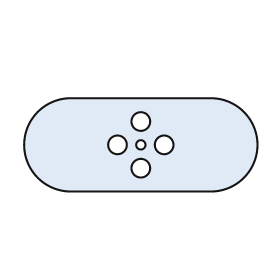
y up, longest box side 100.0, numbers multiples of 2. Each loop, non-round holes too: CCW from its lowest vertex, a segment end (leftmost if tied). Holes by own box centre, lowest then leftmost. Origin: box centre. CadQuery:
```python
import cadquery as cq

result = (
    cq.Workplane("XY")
    .moveTo(-30.0, -20.0)
    .lineTo(30.0, -20.0)
    .threePointArc((50.0, 0.0), (30.0, 20.0))
    .lineTo(-30.0, 20.0)
    .threePointArc((-50.0, 0.0), (-30.0, -20.0))
    .close()
    .moveTo(0.0, -10.0)
    .circle(4.0)
    .moveTo(-10.0, 0.0)
    .circle(4.0)
    .moveTo(0.0, 0.0)
    .circle(2.0)
    .moveTo(10.0, 0.0)
    .circle(4.0)
    .moveTo(0.0, 10.0)
    .circle(4.0)
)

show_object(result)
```